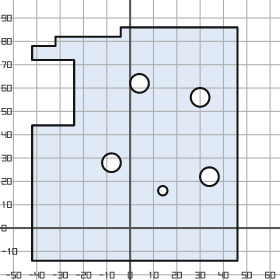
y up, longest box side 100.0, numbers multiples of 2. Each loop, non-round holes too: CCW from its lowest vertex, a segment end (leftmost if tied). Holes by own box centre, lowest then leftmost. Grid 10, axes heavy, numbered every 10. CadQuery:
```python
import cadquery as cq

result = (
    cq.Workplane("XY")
    .moveTo(-42.0, -14.0)
    .lineTo(46.0, -14.0)
    .lineTo(46.0, 86.0)
    .lineTo(-4.0, 86.0)
    .lineTo(-4.0, 82.0)
    .lineTo(-32.0, 82.0)
    .lineTo(-32.0, 78.0)
    .lineTo(-42.0, 78.0)
    .lineTo(-42.0, 72.0)
    .lineTo(-24.0, 72.0)
    .lineTo(-24.0, 44.0)
    .lineTo(-42.0, 44.0)
    .close()
    .moveTo(14.0, 16.0)
    .circle(2.0)
    .moveTo(34.0, 22.0)
    .circle(4.0)
    .moveTo(-8.0, 28.0)
    .circle(4.0)
    .moveTo(30.0, 56.0)
    .circle(4.0)
    .moveTo(4.0, 62.0)
    .circle(4.0)
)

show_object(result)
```